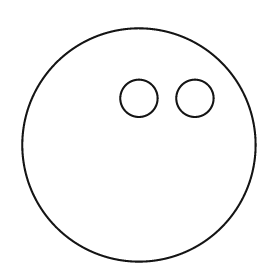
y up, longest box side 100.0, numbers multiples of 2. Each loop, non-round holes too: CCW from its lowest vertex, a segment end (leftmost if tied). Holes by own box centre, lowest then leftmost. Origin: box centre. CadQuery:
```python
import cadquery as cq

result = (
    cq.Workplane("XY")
    .moveTo(0.0, 0.0)
    .circle(50.0)
    .moveTo(0.0, 20.0)
    .circle(8.0)
    .moveTo(24.0, 20.0)
    .circle(8.0)
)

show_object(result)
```